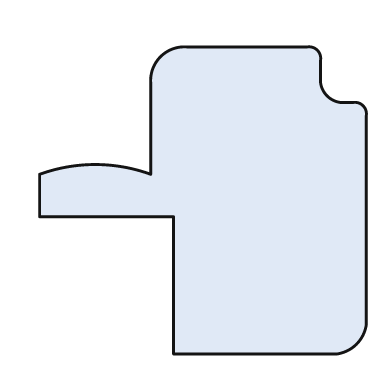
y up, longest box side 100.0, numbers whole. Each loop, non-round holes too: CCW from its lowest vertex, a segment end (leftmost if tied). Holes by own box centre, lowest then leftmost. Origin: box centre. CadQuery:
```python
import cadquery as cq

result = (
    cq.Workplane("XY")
    .moveTo(-9.0, -47.0)
    .lineTo(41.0, -47.0)
    .threePointArc((47.0, -44.0), (50.0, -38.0))
    .lineTo(50.0, 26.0)
    .threePointArc((49.0, 29.0), (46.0, 30.0))
    .lineTo(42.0, 30.0)
    .threePointArc((38.0, 32.0), (36.0, 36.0))
    .lineTo(36.0, 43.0)
    .threePointArc((35.0, 46.0), (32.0, 47.0))
    .lineTo(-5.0, 47.0)
    .threePointArc((-13.0, 44.0), (-16.0, 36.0))
    .lineTo(-16.0, 8.0)
    .threePointArc((-33.0, 11.0), (-50.0, 8.0))
    .lineTo(-50.0, -5.0)
    .lineTo(-9.0, -5.0)
    .close()
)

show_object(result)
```